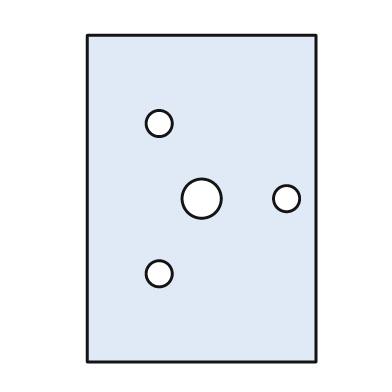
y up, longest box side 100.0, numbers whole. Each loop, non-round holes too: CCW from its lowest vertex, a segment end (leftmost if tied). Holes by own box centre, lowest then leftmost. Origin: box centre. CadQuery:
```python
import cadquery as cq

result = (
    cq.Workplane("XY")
    .moveTo(-35.0, -50.0)
    .lineTo(35.0, -50.0)
    .lineTo(35.0, 50.0)
    .lineTo(-35.0, 50.0)
    .close()
    .moveTo(-13.0, -23.0)
    .circle(4.0)
    .moveTo(0.0, 0.0)
    .circle(6.0)
    .moveTo(26.0, 0.0)
    .circle(4.0)
    .moveTo(-13.0, 23.0)
    .circle(4.0)
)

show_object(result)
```